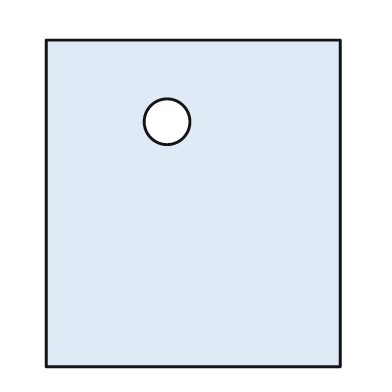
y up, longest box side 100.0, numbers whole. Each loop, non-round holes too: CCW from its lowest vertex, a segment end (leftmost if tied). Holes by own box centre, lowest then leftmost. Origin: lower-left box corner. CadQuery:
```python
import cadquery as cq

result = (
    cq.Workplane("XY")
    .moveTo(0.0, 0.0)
    .lineTo(90.0, 0.0)
    .lineTo(90.0, 100.0)
    .lineTo(0.0, 100.0)
    .close()
    .moveTo(37.0, 75.0)
    .circle(7.0)
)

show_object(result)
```